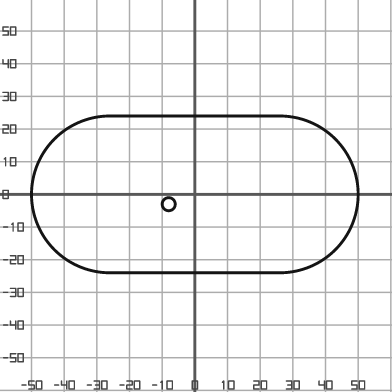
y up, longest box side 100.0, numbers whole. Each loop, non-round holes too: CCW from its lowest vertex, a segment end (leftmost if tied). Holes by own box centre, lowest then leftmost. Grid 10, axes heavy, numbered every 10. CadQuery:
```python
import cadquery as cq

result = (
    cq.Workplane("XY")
    .moveTo(-26.0, -24.0)
    .lineTo(26.0, -24.0)
    .threePointArc((50.0, 0.0), (26.0, 24.0))
    .lineTo(-26.0, 24.0)
    .threePointArc((-50.0, 0.0), (-26.0, -24.0))
    .close()
    .moveTo(-8.0, -3.0)
    .circle(2.0)
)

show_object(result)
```